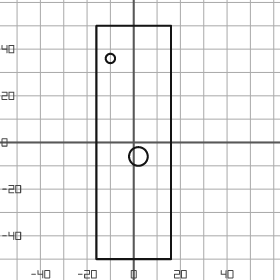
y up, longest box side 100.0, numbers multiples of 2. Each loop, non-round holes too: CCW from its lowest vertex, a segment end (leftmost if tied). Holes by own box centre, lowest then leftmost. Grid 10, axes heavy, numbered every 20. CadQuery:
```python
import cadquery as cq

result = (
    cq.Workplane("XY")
    .moveTo(-16.0, -50.0)
    .lineTo(16.0, -50.0)
    .lineTo(16.0, 50.0)
    .lineTo(-16.0, 50.0)
    .close()
    .moveTo(2.0, -6.0)
    .circle(4.0)
    .moveTo(-10.0, 36.0)
    .circle(2.0)
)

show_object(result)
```